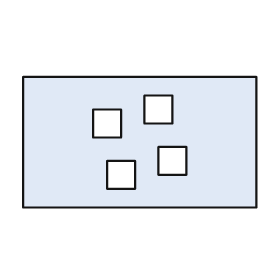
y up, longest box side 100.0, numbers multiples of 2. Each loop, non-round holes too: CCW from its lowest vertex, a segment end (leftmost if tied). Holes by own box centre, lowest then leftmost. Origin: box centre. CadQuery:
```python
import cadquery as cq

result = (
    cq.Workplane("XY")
    .moveTo(-50.0, -28.0)
    .lineTo(50.0, -28.0)
    .lineTo(50.0, 28.0)
    .lineTo(-50.0, 28.0)
    .close()
    .moveTo(-14.0, -20.0)
    .lineTo(-2.0, -20.0)
    .lineTo(-2.0, -8.0)
    .lineTo(-14.0, -8.0)
    .close()
    .moveTo(8.0, -14.0)
    .lineTo(20.0, -14.0)
    .lineTo(20.0, -2.0)
    .lineTo(8.0, -2.0)
    .close()
    .moveTo(-20.0, 2.0)
    .lineTo(-8.0, 2.0)
    .lineTo(-8.0, 14.0)
    .lineTo(-20.0, 14.0)
    .close()
    .moveTo(2.0, 8.0)
    .lineTo(14.0, 8.0)
    .lineTo(14.0, 20.0)
    .lineTo(2.0, 20.0)
    .close()
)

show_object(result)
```